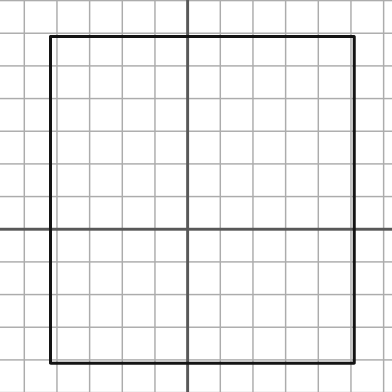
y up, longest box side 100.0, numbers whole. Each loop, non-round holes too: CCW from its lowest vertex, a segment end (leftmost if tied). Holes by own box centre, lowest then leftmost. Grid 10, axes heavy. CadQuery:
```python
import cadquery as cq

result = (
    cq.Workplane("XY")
    .moveTo(-42.0, -41.0)
    .lineTo(51.0, -41.0)
    .lineTo(51.0, 59.0)
    .lineTo(-42.0, 59.0)
    .close()
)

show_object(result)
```